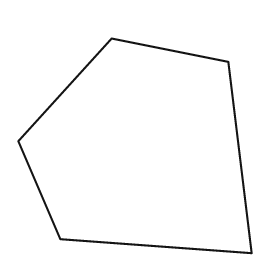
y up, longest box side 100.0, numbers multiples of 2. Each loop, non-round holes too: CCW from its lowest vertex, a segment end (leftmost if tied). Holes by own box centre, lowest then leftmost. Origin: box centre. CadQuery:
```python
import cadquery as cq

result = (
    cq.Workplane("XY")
    .moveTo(50.0, -46.0)
    .lineTo(40.0, 36.0)
    .lineTo(-10.0, 46.0)
    .lineTo(-50.0, 2.0)
    .lineTo(-32.0, -40.0)
    .close()
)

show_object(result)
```